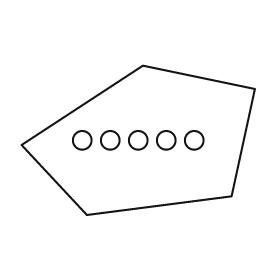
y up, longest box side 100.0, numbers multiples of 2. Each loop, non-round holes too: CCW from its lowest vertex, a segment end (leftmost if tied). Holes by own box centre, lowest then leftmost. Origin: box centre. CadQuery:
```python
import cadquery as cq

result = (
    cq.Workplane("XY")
    .moveTo(-22.0, -32.0)
    .lineTo(40.0, -24.0)
    .lineTo(50.0, 22.0)
    .lineTo(2.0, 32.0)
    .lineTo(-50.0, -2.0)
    .close()
    .moveTo(-24.0, 0.0)
    .circle(4.0)
    .moveTo(-12.0, 0.0)
    .circle(4.0)
    .moveTo(0.0, 0.0)
    .circle(4.0)
    .moveTo(12.0, 0.0)
    .circle(4.0)
    .moveTo(24.0, 0.0)
    .circle(4.0)
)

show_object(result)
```